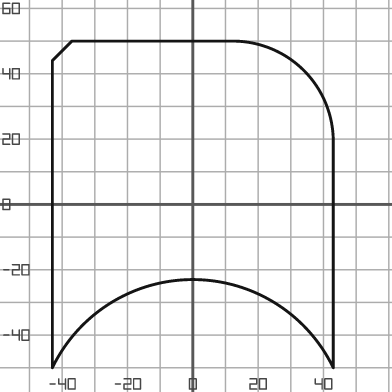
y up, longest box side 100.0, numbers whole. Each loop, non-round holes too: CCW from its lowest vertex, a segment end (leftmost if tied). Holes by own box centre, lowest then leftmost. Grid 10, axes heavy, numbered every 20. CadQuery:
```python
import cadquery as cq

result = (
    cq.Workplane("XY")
    .moveTo(-43.0, -50.0)
    .threePointArc((0.0, -23.0), (43.0, -50.0))
    .lineTo(43.0, 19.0)
    .threePointArc((34.0, 41.0), (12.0, 50.0))
    .lineTo(-37.0, 50.0)
    .lineTo(-43.0, 44.0)
    .close()
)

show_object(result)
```